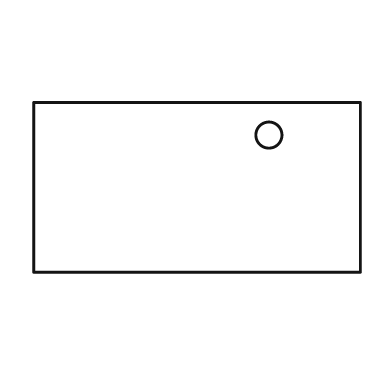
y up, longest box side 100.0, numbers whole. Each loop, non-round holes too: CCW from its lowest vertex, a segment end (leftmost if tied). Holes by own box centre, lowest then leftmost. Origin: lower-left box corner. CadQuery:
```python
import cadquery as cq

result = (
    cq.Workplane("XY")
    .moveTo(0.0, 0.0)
    .lineTo(100.0, 0.0)
    .lineTo(100.0, 52.0)
    .lineTo(0.0, 52.0)
    .close()
    .moveTo(72.0, 42.0)
    .circle(4.0)
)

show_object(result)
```